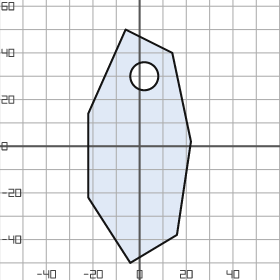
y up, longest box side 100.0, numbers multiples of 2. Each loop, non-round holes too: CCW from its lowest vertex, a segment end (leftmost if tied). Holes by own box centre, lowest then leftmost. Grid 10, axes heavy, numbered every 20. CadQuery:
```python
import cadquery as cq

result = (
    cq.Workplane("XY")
    .moveTo(-4.0, -50.0)
    .lineTo(16.0, -38.0)
    .lineTo(22.0, 2.0)
    .lineTo(14.0, 40.0)
    .lineTo(-6.0, 50.0)
    .lineTo(-22.0, 14.0)
    .lineTo(-22.0, -22.0)
    .close()
    .moveTo(2.0, 30.0)
    .circle(6.0)
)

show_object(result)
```